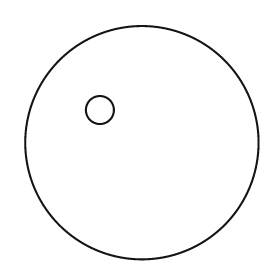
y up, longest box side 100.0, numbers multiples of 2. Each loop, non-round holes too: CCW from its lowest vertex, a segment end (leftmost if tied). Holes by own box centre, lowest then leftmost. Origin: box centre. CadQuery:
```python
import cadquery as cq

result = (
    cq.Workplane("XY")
    .moveTo(0.0, 0.0)
    .circle(50.0)
    .moveTo(-18.0, 14.0)
    .circle(6.0)
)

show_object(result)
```